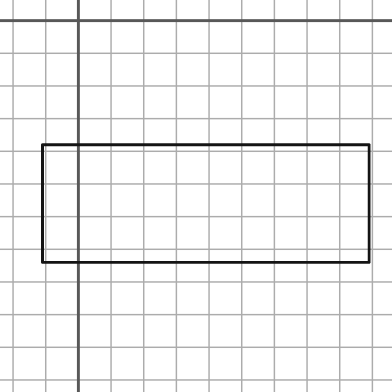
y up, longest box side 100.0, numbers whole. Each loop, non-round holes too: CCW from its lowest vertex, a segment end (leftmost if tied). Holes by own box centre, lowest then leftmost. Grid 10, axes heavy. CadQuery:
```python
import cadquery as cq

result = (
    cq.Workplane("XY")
    .moveTo(-11.0, -74.0)
    .lineTo(89.0, -74.0)
    .lineTo(89.0, -38.0)
    .lineTo(-11.0, -38.0)
    .close()
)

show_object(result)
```